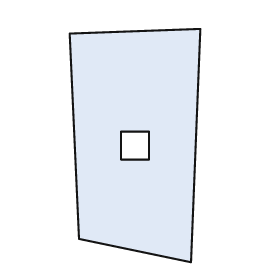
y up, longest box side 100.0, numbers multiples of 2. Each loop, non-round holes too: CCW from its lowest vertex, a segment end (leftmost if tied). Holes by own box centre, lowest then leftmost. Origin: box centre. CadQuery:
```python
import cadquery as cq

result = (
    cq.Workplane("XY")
    .moveTo(24.0, -50.0)
    .lineTo(28.0, 50.0)
    .lineTo(-28.0, 48.0)
    .lineTo(-24.0, -40.0)
    .close()
    .moveTo(-6.0, -6.0)
    .lineTo(6.0, -6.0)
    .lineTo(6.0, 6.0)
    .lineTo(-6.0, 6.0)
    .close()
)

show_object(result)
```